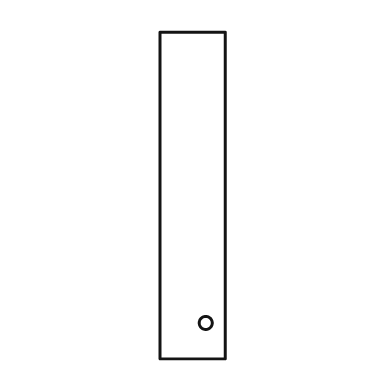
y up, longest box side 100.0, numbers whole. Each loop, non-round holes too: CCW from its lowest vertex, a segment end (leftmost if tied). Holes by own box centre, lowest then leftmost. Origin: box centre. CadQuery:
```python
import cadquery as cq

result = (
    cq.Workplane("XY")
    .moveTo(-10.0, -50.0)
    .lineTo(10.0, -50.0)
    .lineTo(10.0, 50.0)
    .lineTo(-10.0, 50.0)
    .close()
    .moveTo(4.0, -39.0)
    .circle(2.0)
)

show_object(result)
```